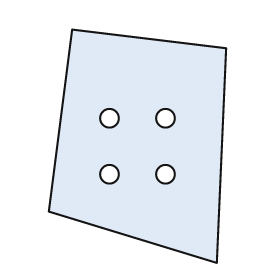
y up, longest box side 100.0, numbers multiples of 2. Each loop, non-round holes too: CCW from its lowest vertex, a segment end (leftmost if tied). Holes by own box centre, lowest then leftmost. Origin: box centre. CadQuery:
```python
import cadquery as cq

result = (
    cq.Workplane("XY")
    .moveTo(34.0, -50.0)
    .lineTo(38.0, 42.0)
    .lineTo(-28.0, 50.0)
    .lineTo(-38.0, -28.0)
    .close()
    .moveTo(-12.0, -12.0)
    .circle(4.0)
    .moveTo(12.0, -12.0)
    .circle(4.0)
    .moveTo(-12.0, 12.0)
    .circle(4.0)
    .moveTo(12.0, 12.0)
    .circle(4.0)
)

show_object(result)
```